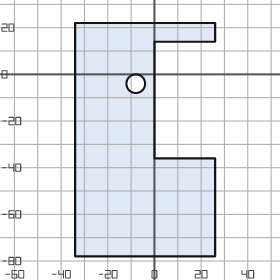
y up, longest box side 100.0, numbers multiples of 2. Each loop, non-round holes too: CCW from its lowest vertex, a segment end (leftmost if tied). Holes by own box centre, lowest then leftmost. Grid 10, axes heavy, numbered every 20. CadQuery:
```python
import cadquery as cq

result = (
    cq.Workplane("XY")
    .moveTo(-34.0, -78.0)
    .lineTo(26.0, -78.0)
    .lineTo(26.0, -36.0)
    .lineTo(0.0, -36.0)
    .lineTo(0.0, 14.0)
    .lineTo(26.0, 14.0)
    .lineTo(26.0, 22.0)
    .lineTo(-34.0, 22.0)
    .close()
    .moveTo(-8.0, -4.0)
    .circle(4.0)
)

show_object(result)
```